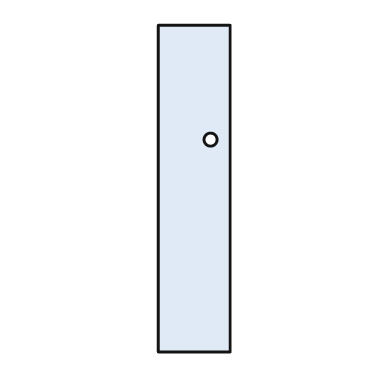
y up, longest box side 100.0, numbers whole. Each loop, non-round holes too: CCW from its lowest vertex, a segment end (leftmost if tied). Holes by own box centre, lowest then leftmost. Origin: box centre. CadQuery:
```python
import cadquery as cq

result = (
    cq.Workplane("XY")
    .moveTo(-11.0, -50.0)
    .lineTo(11.0, -50.0)
    .lineTo(11.0, 50.0)
    .lineTo(-11.0, 50.0)
    .close()
    .moveTo(5.0, 15.0)
    .circle(2.0)
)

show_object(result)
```